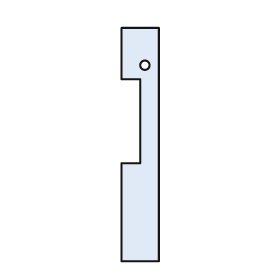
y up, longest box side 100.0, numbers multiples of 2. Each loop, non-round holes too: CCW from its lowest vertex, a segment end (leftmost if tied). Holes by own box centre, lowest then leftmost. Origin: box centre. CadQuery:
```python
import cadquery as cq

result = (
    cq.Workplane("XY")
    .moveTo(-8.0, -50.0)
    .lineTo(8.0, -50.0)
    .lineTo(8.0, 50.0)
    .lineTo(-8.0, 50.0)
    .lineTo(-8.0, 28.0)
    .lineTo(0.0, 28.0)
    .lineTo(0.0, -8.0)
    .lineTo(-8.0, -8.0)
    .close()
    .moveTo(2.0, 34.0)
    .circle(2.0)
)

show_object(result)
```